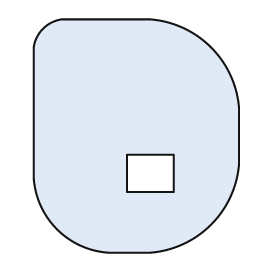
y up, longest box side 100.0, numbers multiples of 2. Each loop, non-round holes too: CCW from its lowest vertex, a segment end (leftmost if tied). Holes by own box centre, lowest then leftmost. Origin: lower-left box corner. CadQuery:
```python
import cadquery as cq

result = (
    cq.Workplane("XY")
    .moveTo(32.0, 0.0)
    .lineTo(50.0, 0.0)
    .threePointArc((76.0, 12.0), (88.0, 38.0))
    .lineTo(88.0, 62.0)
    .threePointArc((76.0, 88.0), (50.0, 100.0))
    .lineTo(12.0, 100.0)
    .threePointArc((4.0, 96.0), (0.0, 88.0))
    .lineTo(0.0, 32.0)
    .threePointArc((10.0, 10.0), (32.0, 0.0))
    .close()
    .moveTo(40.0, 26.0)
    .lineTo(60.0, 26.0)
    .lineTo(60.0, 42.0)
    .lineTo(40.0, 42.0)
    .close()
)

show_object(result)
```